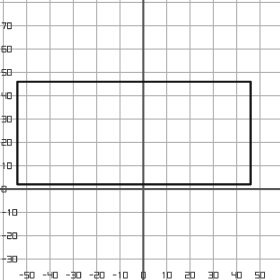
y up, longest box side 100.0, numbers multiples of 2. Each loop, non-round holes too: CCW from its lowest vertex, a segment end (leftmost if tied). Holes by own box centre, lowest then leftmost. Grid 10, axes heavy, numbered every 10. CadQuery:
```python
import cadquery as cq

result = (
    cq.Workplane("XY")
    .moveTo(-54.0, 2.0)
    .lineTo(46.0, 2.0)
    .lineTo(46.0, 46.0)
    .lineTo(-54.0, 46.0)
    .close()
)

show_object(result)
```